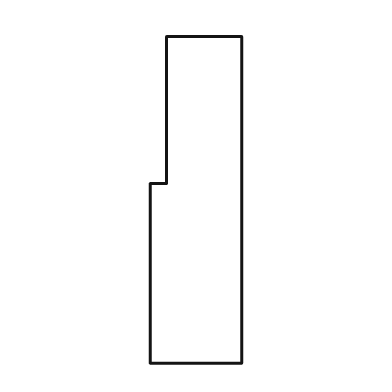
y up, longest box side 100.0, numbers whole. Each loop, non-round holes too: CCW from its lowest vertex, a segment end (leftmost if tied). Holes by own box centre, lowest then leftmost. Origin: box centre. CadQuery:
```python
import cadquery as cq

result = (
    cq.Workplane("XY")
    .moveTo(-14.0, -50.0)
    .lineTo(14.0, -50.0)
    .lineTo(14.0, 50.0)
    .lineTo(-9.0, 50.0)
    .lineTo(-9.0, 5.0)
    .lineTo(-14.0, 5.0)
    .close()
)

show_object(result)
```